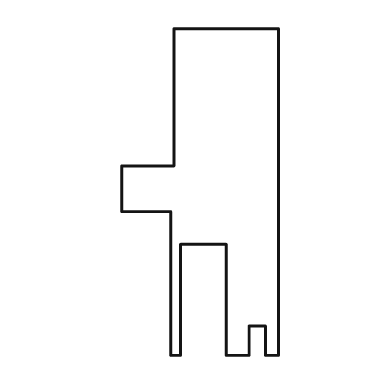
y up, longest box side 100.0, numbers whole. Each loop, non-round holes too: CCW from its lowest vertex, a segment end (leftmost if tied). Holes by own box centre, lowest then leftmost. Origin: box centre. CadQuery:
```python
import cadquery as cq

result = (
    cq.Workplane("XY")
    .moveTo(-9.0, -50.0)
    .lineTo(-6.0, -50.0)
    .lineTo(-6.0, -16.0)
    .lineTo(8.0, -16.0)
    .lineTo(8.0, -50.0)
    .lineTo(15.0, -50.0)
    .lineTo(15.0, -41.0)
    .lineTo(20.0, -41.0)
    .lineTo(20.0, -50.0)
    .lineTo(24.0, -50.0)
    .lineTo(24.0, 50.0)
    .lineTo(-8.0, 50.0)
    .lineTo(-8.0, 8.0)
    .lineTo(-24.0, 8.0)
    .lineTo(-24.0, -6.0)
    .lineTo(-9.0, -6.0)
    .close()
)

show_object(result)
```